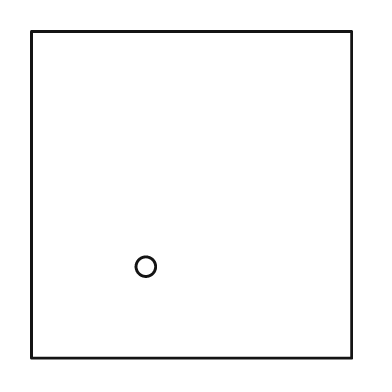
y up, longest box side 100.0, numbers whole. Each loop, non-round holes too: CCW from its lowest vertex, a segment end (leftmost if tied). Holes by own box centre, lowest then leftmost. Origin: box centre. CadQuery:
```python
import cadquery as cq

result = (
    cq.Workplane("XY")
    .moveTo(-49.0, -50.0)
    .lineTo(49.0, -50.0)
    .lineTo(49.0, 50.0)
    .lineTo(-49.0, 50.0)
    .close()
    .moveTo(-14.0, -22.0)
    .circle(3.0)
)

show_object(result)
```